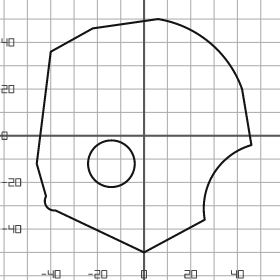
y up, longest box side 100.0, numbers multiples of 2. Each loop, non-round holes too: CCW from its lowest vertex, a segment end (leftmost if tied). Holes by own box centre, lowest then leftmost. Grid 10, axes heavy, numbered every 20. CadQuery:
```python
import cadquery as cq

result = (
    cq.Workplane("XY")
    .moveTo(0.0, -50.0)
    .lineTo(26.0, -36.0)
    .threePointArc((30.0, -16.0), (46.0, -4.0))
    .lineTo(42.0, 20.0)
    .threePointArc((28.0, 40.0), (6.0, 50.0))
    .lineTo(-22.0, 46.0)
    .lineTo(-40.0, 36.0)
    .lineTo(-46.0, -12.0)
    .lineTo(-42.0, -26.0)
    .threePointArc((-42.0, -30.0), (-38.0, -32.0))
    .close()
    .moveTo(-14.0, -12.0)
    .circle(10.0)
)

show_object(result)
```